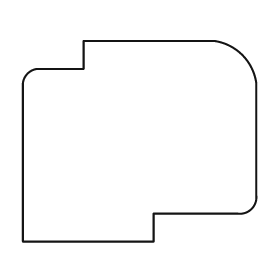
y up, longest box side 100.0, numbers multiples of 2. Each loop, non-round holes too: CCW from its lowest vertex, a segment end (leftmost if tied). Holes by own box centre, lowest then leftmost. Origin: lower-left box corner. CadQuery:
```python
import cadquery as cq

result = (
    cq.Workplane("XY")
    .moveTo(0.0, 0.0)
    .lineTo(56.0, 0.0)
    .lineTo(56.0, 12.0)
    .lineTo(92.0, 12.0)
    .threePointArc((98.0, 14.0), (100.0, 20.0))
    .lineTo(100.0, 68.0)
    .threePointArc((94.0, 80.0), (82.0, 86.0))
    .lineTo(26.0, 86.0)
    .lineTo(26.0, 74.0)
    .lineTo(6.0, 74.0)
    .threePointArc((2.0, 72.0), (0.0, 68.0))
    .close()
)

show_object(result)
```